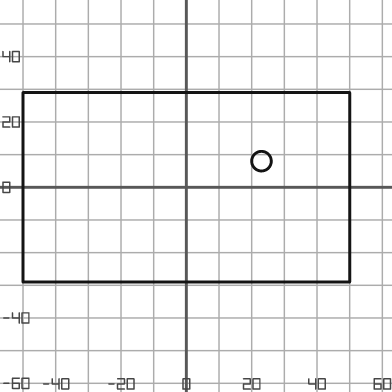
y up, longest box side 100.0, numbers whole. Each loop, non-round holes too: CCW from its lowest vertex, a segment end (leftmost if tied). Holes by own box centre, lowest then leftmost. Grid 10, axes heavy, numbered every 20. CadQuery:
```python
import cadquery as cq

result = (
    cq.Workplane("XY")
    .moveTo(-50.0, -29.0)
    .lineTo(50.0, -29.0)
    .lineTo(50.0, 29.0)
    .lineTo(-50.0, 29.0)
    .close()
    .moveTo(23.0, 8.0)
    .circle(3.0)
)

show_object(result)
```